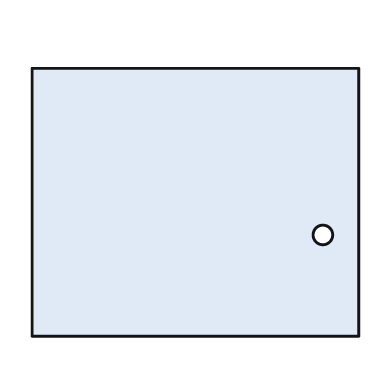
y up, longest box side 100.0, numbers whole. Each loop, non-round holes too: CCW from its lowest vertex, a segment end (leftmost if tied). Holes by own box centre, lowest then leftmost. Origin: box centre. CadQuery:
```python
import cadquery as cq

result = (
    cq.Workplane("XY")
    .moveTo(-50.0, -41.0)
    .lineTo(50.0, -41.0)
    .lineTo(50.0, 41.0)
    .lineTo(-50.0, 41.0)
    .close()
    .moveTo(39.0, -10.0)
    .circle(3.0)
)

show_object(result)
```